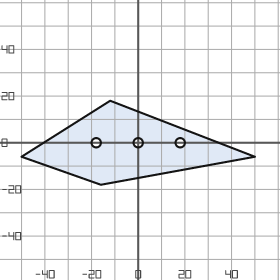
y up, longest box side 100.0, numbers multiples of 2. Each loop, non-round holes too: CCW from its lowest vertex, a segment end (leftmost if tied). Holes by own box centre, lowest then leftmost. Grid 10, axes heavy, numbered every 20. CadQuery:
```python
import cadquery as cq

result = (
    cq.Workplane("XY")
    .moveTo(-16.0, -18.0)
    .lineTo(50.0, -6.0)
    .lineTo(-12.0, 18.0)
    .lineTo(-50.0, -6.0)
    .close()
    .moveTo(-18.0, 0.0)
    .circle(2.0)
    .moveTo(0.0, 0.0)
    .circle(2.0)
    .moveTo(18.0, 0.0)
    .circle(2.0)
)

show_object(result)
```